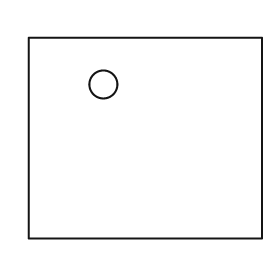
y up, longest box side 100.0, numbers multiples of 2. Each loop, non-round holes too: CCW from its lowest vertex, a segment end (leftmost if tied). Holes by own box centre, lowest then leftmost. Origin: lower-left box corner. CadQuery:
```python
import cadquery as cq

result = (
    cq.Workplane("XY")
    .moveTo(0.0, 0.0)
    .lineTo(100.0, 0.0)
    .lineTo(100.0, 86.0)
    .lineTo(0.0, 86.0)
    .close()
    .moveTo(32.0, 66.0)
    .circle(6.0)
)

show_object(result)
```